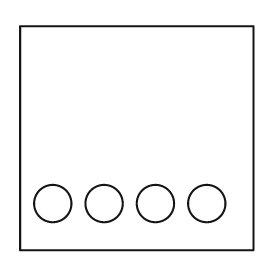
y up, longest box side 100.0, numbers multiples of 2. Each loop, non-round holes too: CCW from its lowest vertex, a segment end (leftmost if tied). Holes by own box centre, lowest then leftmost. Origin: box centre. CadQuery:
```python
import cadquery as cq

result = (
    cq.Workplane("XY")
    .moveTo(-50.0, -48.0)
    .lineTo(50.0, -48.0)
    .lineTo(50.0, 48.0)
    .lineTo(-50.0, 48.0)
    .close()
    .moveTo(-36.0, -28.0)
    .circle(8.0)
    .moveTo(-14.0, -28.0)
    .circle(8.0)
    .moveTo(8.0, -28.0)
    .circle(8.0)
    .moveTo(30.0, -28.0)
    .circle(8.0)
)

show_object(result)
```